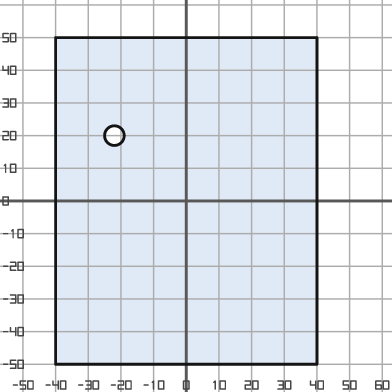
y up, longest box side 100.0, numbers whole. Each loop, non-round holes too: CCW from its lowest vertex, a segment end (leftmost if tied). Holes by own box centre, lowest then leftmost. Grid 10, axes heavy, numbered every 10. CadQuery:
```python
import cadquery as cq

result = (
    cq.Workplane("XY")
    .moveTo(-40.0, -50.0)
    .lineTo(40.0, -50.0)
    .lineTo(40.0, 50.0)
    .lineTo(-40.0, 50.0)
    .close()
    .moveTo(-22.0, 20.0)
    .circle(3.0)
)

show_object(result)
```